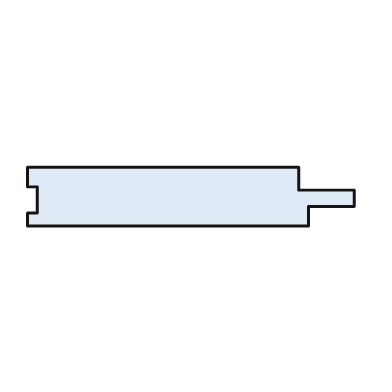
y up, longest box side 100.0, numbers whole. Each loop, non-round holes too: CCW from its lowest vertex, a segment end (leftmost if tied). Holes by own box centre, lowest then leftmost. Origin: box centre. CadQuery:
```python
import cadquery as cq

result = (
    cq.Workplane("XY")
    .moveTo(-50.0, -9.0)
    .lineTo(36.0, -9.0)
    .lineTo(36.0, -3.0)
    .lineTo(50.0, -3.0)
    .lineTo(50.0, 2.0)
    .lineTo(33.0, 2.0)
    .lineTo(33.0, 9.0)
    .lineTo(-50.0, 9.0)
    .lineTo(-50.0, 3.0)
    .lineTo(-47.0, 3.0)
    .lineTo(-47.0, -5.0)
    .lineTo(-50.0, -5.0)
    .close()
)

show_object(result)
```